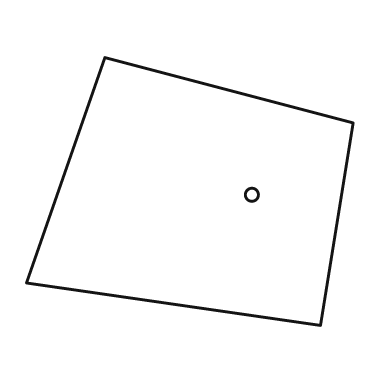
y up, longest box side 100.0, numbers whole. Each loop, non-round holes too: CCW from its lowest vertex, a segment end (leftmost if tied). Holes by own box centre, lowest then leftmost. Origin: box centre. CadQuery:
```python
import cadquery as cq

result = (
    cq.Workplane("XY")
    .moveTo(40.0, -41.0)
    .lineTo(50.0, 21.0)
    .lineTo(-26.0, 41.0)
    .lineTo(-50.0, -28.0)
    .close()
    .moveTo(19.0, -1.0)
    .circle(2.0)
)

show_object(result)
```